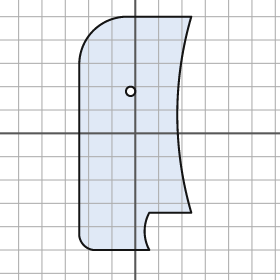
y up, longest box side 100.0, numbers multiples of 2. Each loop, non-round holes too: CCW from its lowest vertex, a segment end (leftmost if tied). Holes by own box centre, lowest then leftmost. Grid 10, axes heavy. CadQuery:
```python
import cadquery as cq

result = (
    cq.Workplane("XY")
    .moveTo(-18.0, -50.0)
    .lineTo(6.0, -50.0)
    .threePointArc((4.0, -42.0), (6.0, -34.0))
    .lineTo(24.0, -34.0)
    .threePointArc((18.0, 8.0), (24.0, 50.0))
    .lineTo(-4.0, 50.0)
    .threePointArc((-18.0, 44.0), (-24.0, 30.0))
    .lineTo(-24.0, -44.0)
    .threePointArc((-22.0, -48.0), (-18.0, -50.0))
    .close()
    .moveTo(-2.0, 18.0)
    .circle(2.0)
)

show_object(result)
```